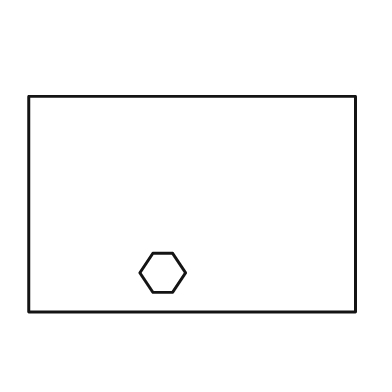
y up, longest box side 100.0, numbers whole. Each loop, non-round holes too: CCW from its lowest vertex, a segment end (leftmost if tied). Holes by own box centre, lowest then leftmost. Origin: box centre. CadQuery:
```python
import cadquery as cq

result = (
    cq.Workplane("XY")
    .moveTo(-50.0, -33.0)
    .lineTo(50.0, -33.0)
    .lineTo(50.0, 33.0)
    .lineTo(-50.0, 33.0)
    .close()
    .moveTo(-12.0, -27.0)
    .lineTo(-6.0, -27.0)
    .lineTo(-2.0, -21.0)
    .lineTo(-6.0, -15.0)
    .lineTo(-12.0, -15.0)
    .lineTo(-16.0, -21.0)
    .close()
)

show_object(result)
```